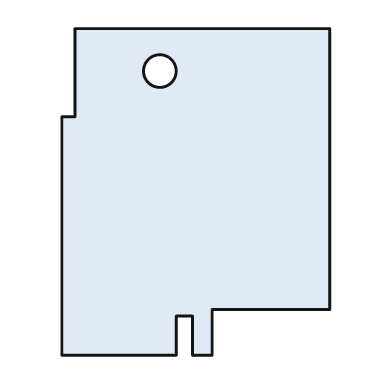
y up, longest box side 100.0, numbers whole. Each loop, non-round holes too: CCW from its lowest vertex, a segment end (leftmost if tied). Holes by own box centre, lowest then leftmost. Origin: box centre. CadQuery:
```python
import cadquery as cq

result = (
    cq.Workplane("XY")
    .moveTo(-41.0, -50.0)
    .lineTo(-6.0, -50.0)
    .lineTo(-6.0, -38.0)
    .lineTo(-1.0, -38.0)
    .lineTo(-1.0, -50.0)
    .lineTo(5.0, -50.0)
    .lineTo(5.0, -36.0)
    .lineTo(41.0, -36.0)
    .lineTo(41.0, 50.0)
    .lineTo(-37.0, 50.0)
    .lineTo(-37.0, 23.0)
    .lineTo(-41.0, 23.0)
    .close()
    .moveTo(-11.0, 37.0)
    .circle(5.0)
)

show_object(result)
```